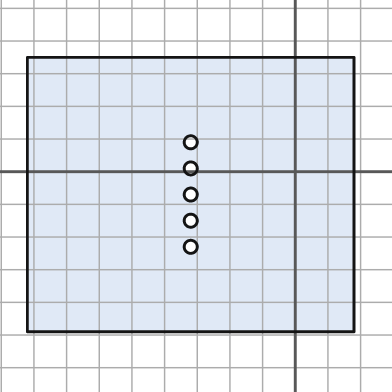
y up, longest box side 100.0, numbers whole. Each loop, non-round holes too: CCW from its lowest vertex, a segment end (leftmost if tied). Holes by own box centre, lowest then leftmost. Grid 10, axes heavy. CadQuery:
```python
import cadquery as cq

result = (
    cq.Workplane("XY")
    .moveTo(-82.0, -49.0)
    .lineTo(18.0, -49.0)
    .lineTo(18.0, 35.0)
    .lineTo(-82.0, 35.0)
    .close()
    .moveTo(-32.0, -23.0)
    .circle(2.0)
    .moveTo(-32.0, -15.0)
    .circle(2.0)
    .moveTo(-32.0, -7.0)
    .circle(2.0)
    .moveTo(-32.0, 1.0)
    .circle(2.0)
    .moveTo(-32.0, 9.0)
    .circle(2.0)
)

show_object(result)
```